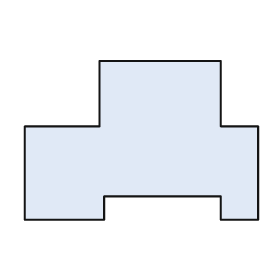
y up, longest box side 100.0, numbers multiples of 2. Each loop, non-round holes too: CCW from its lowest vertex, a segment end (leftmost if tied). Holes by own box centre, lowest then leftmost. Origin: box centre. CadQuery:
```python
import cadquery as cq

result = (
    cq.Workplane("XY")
    .moveTo(-50.0, -34.0)
    .lineTo(-16.0, -34.0)
    .lineTo(-16.0, -24.0)
    .lineTo(34.0, -24.0)
    .lineTo(34.0, -34.0)
    .lineTo(50.0, -34.0)
    .lineTo(50.0, 6.0)
    .lineTo(34.0, 6.0)
    .lineTo(34.0, 34.0)
    .lineTo(-18.0, 34.0)
    .lineTo(-18.0, 6.0)
    .lineTo(-50.0, 6.0)
    .close()
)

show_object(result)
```